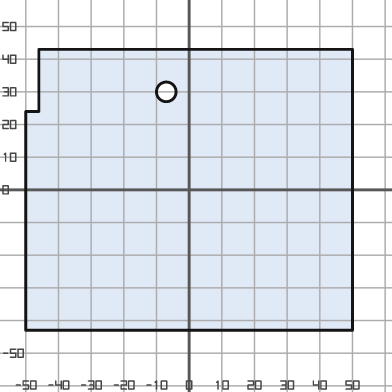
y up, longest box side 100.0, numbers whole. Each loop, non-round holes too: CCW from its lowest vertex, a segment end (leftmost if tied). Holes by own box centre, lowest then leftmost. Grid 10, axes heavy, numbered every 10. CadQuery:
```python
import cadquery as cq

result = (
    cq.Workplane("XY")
    .moveTo(-50.0, -43.0)
    .lineTo(50.0, -43.0)
    .lineTo(50.0, 43.0)
    .lineTo(-46.0, 43.0)
    .lineTo(-46.0, 24.0)
    .lineTo(-50.0, 24.0)
    .close()
    .moveTo(-7.0, 30.0)
    .circle(3.0)
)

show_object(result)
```